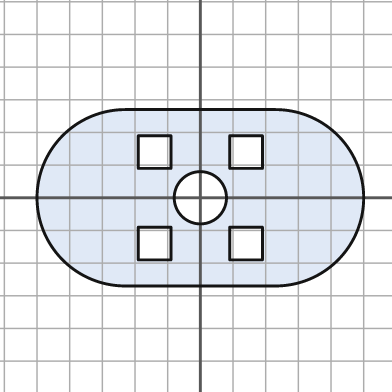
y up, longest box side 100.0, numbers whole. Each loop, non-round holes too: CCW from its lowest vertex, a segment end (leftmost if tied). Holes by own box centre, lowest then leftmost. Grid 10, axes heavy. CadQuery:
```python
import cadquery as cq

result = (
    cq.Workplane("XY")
    .moveTo(-23.0, -27.0)
    .lineTo(23.0, -27.0)
    .threePointArc((50.0, 0.0), (23.0, 27.0))
    .lineTo(-23.0, 27.0)
    .threePointArc((-50.0, 0.0), (-23.0, -27.0))
    .close()
    .moveTo(-19.0, -19.0)
    .lineTo(-9.0, -19.0)
    .lineTo(-9.0, -9.0)
    .lineTo(-19.0, -9.0)
    .close()
    .moveTo(9.0, -19.0)
    .lineTo(19.0, -19.0)
    .lineTo(19.0, -9.0)
    .lineTo(9.0, -9.0)
    .close()
    .moveTo(0.0, 0.0)
    .circle(8.0)
    .moveTo(-19.0, 9.0)
    .lineTo(-9.0, 9.0)
    .lineTo(-9.0, 19.0)
    .lineTo(-19.0, 19.0)
    .close()
    .moveTo(9.0, 9.0)
    .lineTo(19.0, 9.0)
    .lineTo(19.0, 19.0)
    .lineTo(9.0, 19.0)
    .close()
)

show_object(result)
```